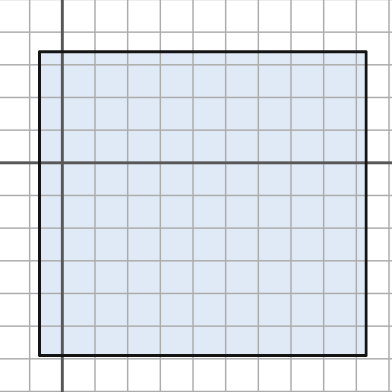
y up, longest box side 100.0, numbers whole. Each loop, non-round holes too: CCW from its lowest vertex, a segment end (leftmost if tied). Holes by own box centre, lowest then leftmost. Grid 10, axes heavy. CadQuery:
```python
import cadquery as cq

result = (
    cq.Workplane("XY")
    .moveTo(-7.0, -59.0)
    .lineTo(93.0, -59.0)
    .lineTo(93.0, 34.0)
    .lineTo(-7.0, 34.0)
    .close()
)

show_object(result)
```